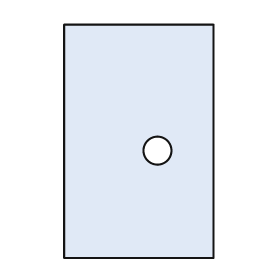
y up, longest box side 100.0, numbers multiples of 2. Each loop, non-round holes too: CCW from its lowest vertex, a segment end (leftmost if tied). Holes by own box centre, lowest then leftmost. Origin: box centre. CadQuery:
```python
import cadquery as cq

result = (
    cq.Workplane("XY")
    .moveTo(-32.0, -50.0)
    .lineTo(32.0, -50.0)
    .lineTo(32.0, 50.0)
    .lineTo(-32.0, 50.0)
    .close()
    .moveTo(8.0, -4.0)
    .circle(6.0)
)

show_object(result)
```